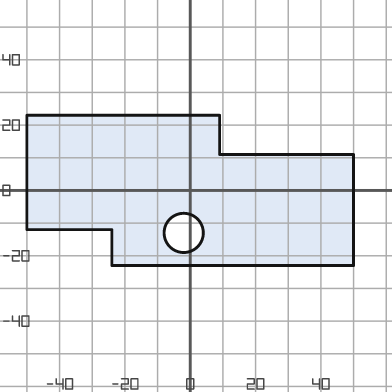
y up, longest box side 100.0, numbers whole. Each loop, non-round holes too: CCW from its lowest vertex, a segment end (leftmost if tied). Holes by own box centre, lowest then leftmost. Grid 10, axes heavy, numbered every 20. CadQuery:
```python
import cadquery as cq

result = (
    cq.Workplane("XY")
    .moveTo(-24.0, -23.0)
    .lineTo(50.0, -23.0)
    .lineTo(50.0, 11.0)
    .lineTo(9.0, 11.0)
    .lineTo(9.0, 23.0)
    .lineTo(-50.0, 23.0)
    .lineTo(-50.0, -12.0)
    .lineTo(-24.0, -12.0)
    .close()
    .moveTo(-2.0, -13.0)
    .circle(6.0)
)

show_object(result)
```